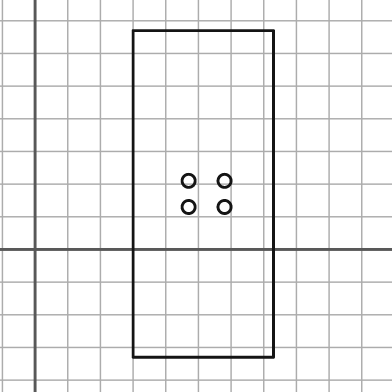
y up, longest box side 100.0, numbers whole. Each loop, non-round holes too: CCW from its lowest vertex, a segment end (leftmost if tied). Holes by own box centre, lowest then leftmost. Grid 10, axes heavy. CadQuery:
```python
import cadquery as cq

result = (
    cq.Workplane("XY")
    .moveTo(30.0, -33.0)
    .lineTo(73.0, -33.0)
    .lineTo(73.0, 67.0)
    .lineTo(30.0, 67.0)
    .close()
    .moveTo(47.0, 13.0)
    .circle(2.0)
    .moveTo(58.0, 13.0)
    .circle(2.0)
    .moveTo(47.0, 21.0)
    .circle(2.0)
    .moveTo(58.0, 21.0)
    .circle(2.0)
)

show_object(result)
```